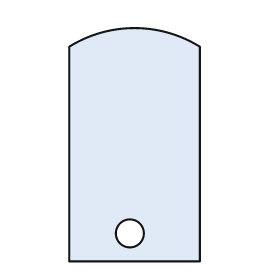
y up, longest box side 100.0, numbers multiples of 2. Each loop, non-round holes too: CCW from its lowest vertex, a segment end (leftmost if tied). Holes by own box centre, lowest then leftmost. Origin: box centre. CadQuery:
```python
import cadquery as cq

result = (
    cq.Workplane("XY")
    .moveTo(-28.0, -50.0)
    .lineTo(28.0, -50.0)
    .lineTo(28.0, 42.0)
    .threePointArc((0.0, 50.0), (-28.0, 42.0))
    .close()
    .moveTo(-2.0, -38.0)
    .circle(6.0)
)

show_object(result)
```